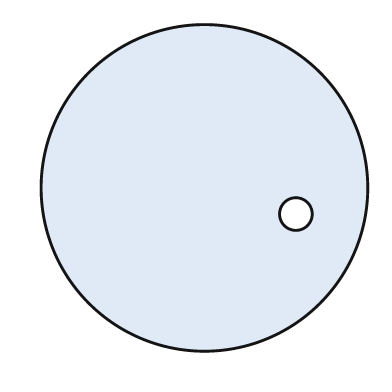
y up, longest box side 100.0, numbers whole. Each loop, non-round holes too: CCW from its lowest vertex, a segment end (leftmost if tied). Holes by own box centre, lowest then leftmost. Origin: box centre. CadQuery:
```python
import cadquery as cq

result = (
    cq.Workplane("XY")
    .moveTo(0.0, 0.0)
    .circle(50.0)
    .moveTo(28.0, -8.0)
    .circle(5.0)
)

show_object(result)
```